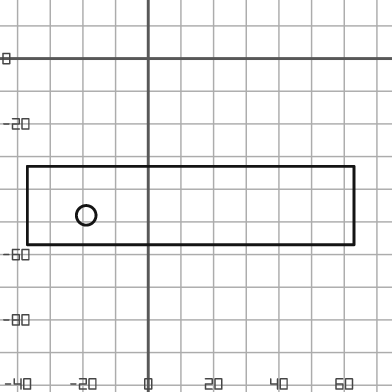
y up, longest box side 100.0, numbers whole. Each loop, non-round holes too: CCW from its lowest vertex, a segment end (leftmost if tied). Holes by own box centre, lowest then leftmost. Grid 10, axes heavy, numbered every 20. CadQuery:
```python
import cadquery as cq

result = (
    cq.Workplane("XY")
    .moveTo(-37.0, -57.0)
    .lineTo(63.0, -57.0)
    .lineTo(63.0, -33.0)
    .lineTo(-37.0, -33.0)
    .close()
    .moveTo(-19.0, -48.0)
    .circle(3.0)
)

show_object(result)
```